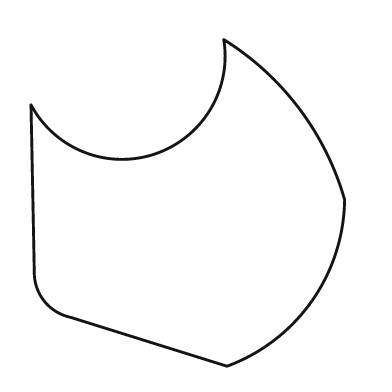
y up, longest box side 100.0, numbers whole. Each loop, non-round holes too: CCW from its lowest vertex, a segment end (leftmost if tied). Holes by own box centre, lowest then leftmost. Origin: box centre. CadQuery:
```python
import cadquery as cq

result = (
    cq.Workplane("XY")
    .moveTo(12.0, -50.0)
    .threePointArc((38.0, -30.0), (48.0, 1.0))
    .threePointArc((34.0, 29.0), (11.0, 50.0))
    .threePointArc((-10.0, 15.0), (-48.0, 30.0))
    .lineTo(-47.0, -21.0)
    .threePointArc((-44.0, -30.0), (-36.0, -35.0))
    .close()
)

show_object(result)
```